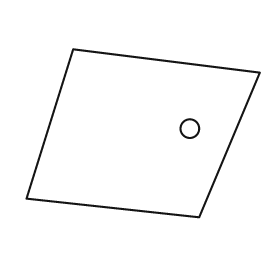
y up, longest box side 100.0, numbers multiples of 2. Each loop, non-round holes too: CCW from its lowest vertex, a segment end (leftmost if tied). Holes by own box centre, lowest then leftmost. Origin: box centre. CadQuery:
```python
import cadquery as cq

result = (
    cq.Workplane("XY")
    .moveTo(24.0, -36.0)
    .lineTo(50.0, 26.0)
    .lineTo(-30.0, 36.0)
    .lineTo(-50.0, -28.0)
    .close()
    .moveTo(20.0, 2.0)
    .circle(4.0)
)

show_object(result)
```